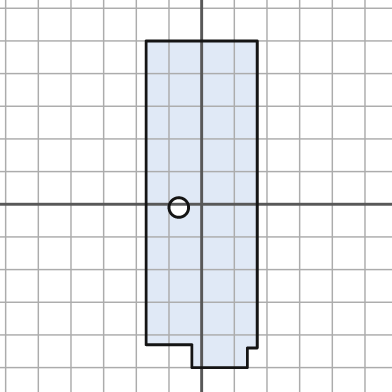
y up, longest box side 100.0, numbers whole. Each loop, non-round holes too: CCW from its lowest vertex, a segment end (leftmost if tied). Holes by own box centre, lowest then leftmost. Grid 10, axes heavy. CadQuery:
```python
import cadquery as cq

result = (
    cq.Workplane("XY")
    .moveTo(-3.0, -50.0)
    .lineTo(14.0, -50.0)
    .lineTo(14.0, -44.0)
    .lineTo(17.0, -44.0)
    .lineTo(17.0, 50.0)
    .lineTo(-17.0, 50.0)
    .lineTo(-17.0, -43.0)
    .lineTo(-3.0, -43.0)
    .close()
    .moveTo(-7.0, -1.0)
    .circle(3.0)
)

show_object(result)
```